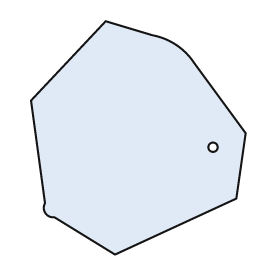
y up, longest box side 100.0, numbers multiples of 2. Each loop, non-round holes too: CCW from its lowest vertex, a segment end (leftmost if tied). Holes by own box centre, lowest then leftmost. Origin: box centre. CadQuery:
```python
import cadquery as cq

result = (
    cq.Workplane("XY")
    .moveTo(-10.0, -50.0)
    .lineTo(42.0, -26.0)
    .lineTo(46.0, 2.0)
    .lineTo(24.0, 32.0)
    .threePointArc((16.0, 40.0), (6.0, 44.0))
    .lineTo(-14.0, 50.0)
    .lineTo(-46.0, 16.0)
    .lineTo(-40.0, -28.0)
    .threePointArc((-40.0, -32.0), (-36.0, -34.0))
    .close()
    .moveTo(32.0, -4.0)
    .circle(2.0)
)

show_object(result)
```